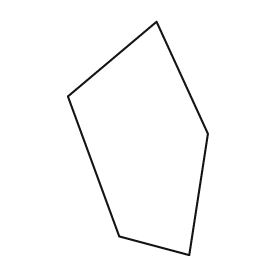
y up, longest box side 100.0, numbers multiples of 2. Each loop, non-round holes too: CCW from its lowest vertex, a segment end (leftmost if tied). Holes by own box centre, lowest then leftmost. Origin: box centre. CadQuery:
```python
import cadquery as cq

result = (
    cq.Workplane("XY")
    .moveTo(22.0, -50.0)
    .lineTo(30.0, 2.0)
    .lineTo(8.0, 50.0)
    .lineTo(-30.0, 18.0)
    .lineTo(-8.0, -42.0)
    .close()
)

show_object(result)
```